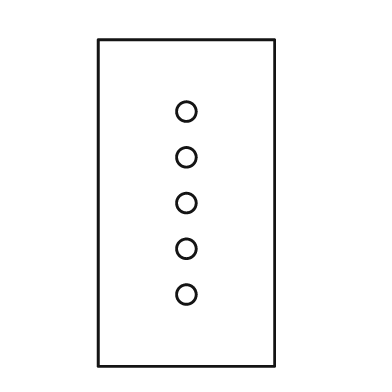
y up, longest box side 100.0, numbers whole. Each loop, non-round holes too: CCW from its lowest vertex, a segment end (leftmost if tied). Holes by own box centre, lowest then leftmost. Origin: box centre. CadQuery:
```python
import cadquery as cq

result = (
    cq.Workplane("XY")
    .moveTo(-27.0, -50.0)
    .lineTo(27.0, -50.0)
    .lineTo(27.0, 50.0)
    .lineTo(-27.0, 50.0)
    .close()
    .moveTo(0.0, -28.0)
    .circle(3.0)
    .moveTo(0.0, -14.0)
    .circle(3.0)
    .moveTo(0.0, 0.0)
    .circle(3.0)
    .moveTo(0.0, 14.0)
    .circle(3.0)
    .moveTo(0.0, 28.0)
    .circle(3.0)
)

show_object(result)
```